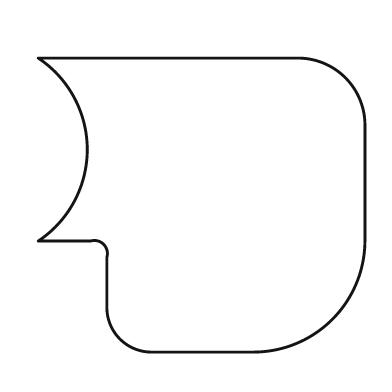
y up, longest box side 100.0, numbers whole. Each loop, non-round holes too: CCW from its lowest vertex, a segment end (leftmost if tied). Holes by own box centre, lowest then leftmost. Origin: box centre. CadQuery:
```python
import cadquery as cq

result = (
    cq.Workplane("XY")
    .moveTo(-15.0, -45.0)
    .lineTo(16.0, -45.0)
    .threePointArc((40.0, -35.0), (50.0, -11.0))
    .lineTo(50.0, 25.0)
    .threePointArc((44.0, 39.0), (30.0, 45.0))
    .lineTo(-50.0, 45.0)
    .threePointArc((-35.0, 17.0), (-50.0, -11.0))
    .lineTo(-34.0, -11.0)
    .threePointArc((-30.0, -12.0), (-29.0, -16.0))
    .lineTo(-29.0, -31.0)
    .threePointArc((-25.0, -41.0), (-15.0, -45.0))
    .close()
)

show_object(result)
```